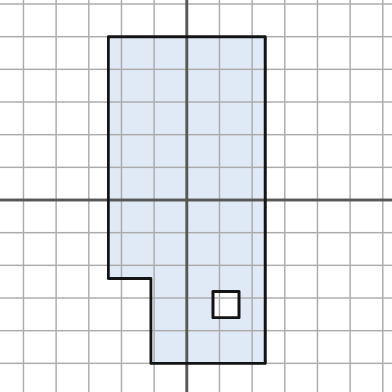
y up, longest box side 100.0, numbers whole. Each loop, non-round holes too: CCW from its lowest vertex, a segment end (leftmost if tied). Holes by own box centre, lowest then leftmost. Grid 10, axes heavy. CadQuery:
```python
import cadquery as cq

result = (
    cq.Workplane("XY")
    .moveTo(-11.0, -50.0)
    .lineTo(24.0, -50.0)
    .lineTo(24.0, 50.0)
    .lineTo(-24.0, 50.0)
    .lineTo(-24.0, -24.0)
    .lineTo(-11.0, -24.0)
    .close()
    .moveTo(8.0, -36.0)
    .lineTo(16.0, -36.0)
    .lineTo(16.0, -28.0)
    .lineTo(8.0, -28.0)
    .close()
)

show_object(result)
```